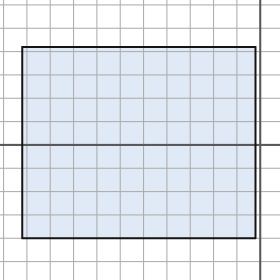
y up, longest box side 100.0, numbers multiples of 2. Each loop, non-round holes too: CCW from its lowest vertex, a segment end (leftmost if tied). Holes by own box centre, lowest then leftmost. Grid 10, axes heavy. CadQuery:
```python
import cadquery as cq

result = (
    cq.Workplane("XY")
    .moveTo(-102.0, -40.0)
    .lineTo(-2.0, -40.0)
    .lineTo(-2.0, 42.0)
    .lineTo(-102.0, 42.0)
    .close()
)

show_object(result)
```